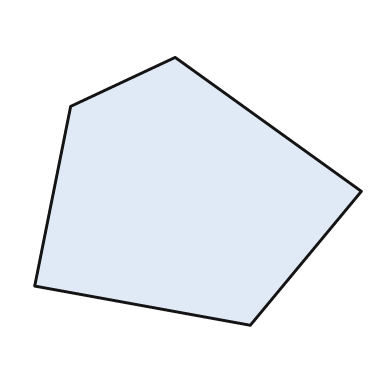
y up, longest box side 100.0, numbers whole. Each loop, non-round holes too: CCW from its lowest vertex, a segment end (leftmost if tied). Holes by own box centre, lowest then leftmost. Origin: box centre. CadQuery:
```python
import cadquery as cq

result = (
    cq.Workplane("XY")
    .moveTo(16.0, -41.0)
    .lineTo(50.0, 0.0)
    .lineTo(-7.0, 41.0)
    .lineTo(-39.0, 26.0)
    .lineTo(-50.0, -29.0)
    .close()
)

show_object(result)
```